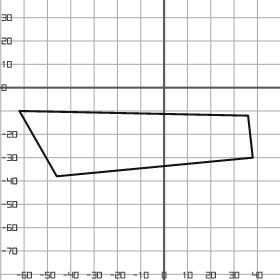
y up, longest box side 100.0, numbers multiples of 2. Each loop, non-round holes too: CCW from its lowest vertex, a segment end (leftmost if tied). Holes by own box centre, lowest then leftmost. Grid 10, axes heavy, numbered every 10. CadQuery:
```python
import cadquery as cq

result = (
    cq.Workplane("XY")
    .moveTo(-46.0, -38.0)
    .lineTo(38.0, -30.0)
    .lineTo(36.0, -12.0)
    .lineTo(-62.0, -10.0)
    .close()
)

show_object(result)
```